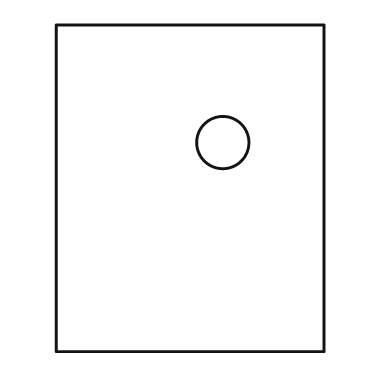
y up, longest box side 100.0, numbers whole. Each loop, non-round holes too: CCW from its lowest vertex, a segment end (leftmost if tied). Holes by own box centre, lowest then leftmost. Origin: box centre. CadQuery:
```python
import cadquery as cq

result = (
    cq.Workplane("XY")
    .moveTo(-41.0, -50.0)
    .lineTo(41.0, -50.0)
    .lineTo(41.0, 50.0)
    .lineTo(-41.0, 50.0)
    .close()
    .moveTo(10.0, 14.0)
    .circle(8.0)
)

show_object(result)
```